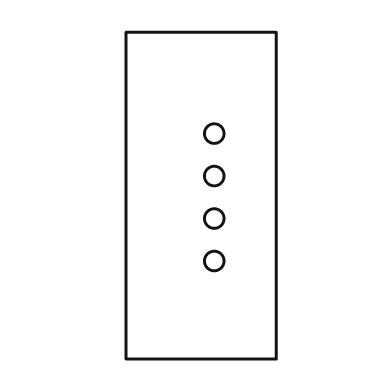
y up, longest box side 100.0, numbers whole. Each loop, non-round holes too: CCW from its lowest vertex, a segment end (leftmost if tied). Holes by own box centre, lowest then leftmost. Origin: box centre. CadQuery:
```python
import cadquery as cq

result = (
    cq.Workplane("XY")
    .moveTo(-23.0, -50.0)
    .lineTo(23.0, -50.0)
    .lineTo(23.0, 50.0)
    .lineTo(-23.0, 50.0)
    .close()
    .moveTo(4.0, -20.0)
    .circle(3.0)
    .moveTo(4.0, -7.0)
    .circle(3.0)
    .moveTo(4.0, 6.0)
    .circle(3.0)
    .moveTo(4.0, 19.0)
    .circle(3.0)
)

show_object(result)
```